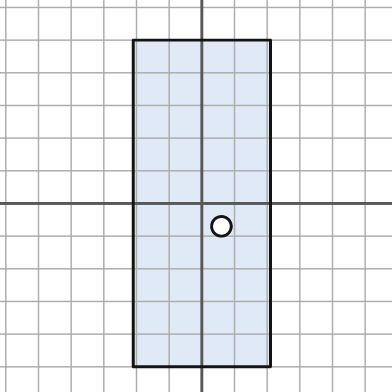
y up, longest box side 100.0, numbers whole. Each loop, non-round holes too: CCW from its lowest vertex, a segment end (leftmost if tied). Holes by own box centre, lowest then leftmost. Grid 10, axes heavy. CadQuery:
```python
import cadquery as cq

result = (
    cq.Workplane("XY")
    .moveTo(-21.0, -50.0)
    .lineTo(21.0, -50.0)
    .lineTo(21.0, 50.0)
    .lineTo(-21.0, 50.0)
    .close()
    .moveTo(6.0, -7.0)
    .circle(3.0)
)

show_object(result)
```